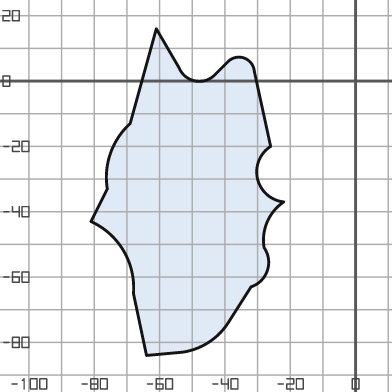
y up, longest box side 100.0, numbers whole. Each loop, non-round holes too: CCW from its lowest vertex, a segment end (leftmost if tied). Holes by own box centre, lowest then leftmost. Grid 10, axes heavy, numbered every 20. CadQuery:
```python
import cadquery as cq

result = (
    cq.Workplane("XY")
    .moveTo(-64.0, -84.0)
    .lineTo(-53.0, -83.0)
    .threePointArc((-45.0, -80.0), (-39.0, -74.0))
    .lineTo(-32.0, -63.0)
    .threePointArc((-27.0, -58.0), (-28.0, -51.0))
    .threePointArc((-27.0, -43.0), (-22.0, -37.0))
    .threePointArc((-30.0, -30.0), (-26.0, -20.0))
    .lineTo(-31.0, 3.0)
    .threePointArc((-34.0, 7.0), (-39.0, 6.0))
    .lineTo(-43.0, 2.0)
    .threePointArc((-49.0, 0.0), (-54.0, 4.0))
    .lineTo(-61.0, 16.0)
    .lineTo(-69.0, -13.0)
    .threePointArc((-75.0, -22.0), (-76.0, -33.0))
    .lineTo(-81.0, -43.0)
    .threePointArc((-71.0, -52.0), (-68.0, -65.0))
    .close()
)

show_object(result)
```